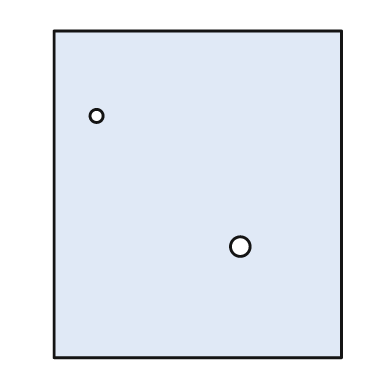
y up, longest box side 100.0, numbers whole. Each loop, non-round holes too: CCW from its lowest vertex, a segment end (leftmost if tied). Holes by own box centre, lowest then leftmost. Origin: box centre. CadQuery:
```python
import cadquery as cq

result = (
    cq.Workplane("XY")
    .moveTo(-44.0, -50.0)
    .lineTo(44.0, -50.0)
    .lineTo(44.0, 50.0)
    .lineTo(-44.0, 50.0)
    .close()
    .moveTo(13.0, -16.0)
    .circle(3.0)
    .moveTo(-31.0, 24.0)
    .circle(2.0)
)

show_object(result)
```